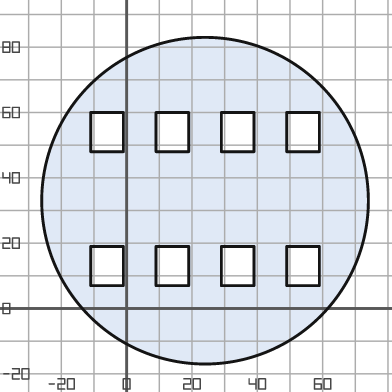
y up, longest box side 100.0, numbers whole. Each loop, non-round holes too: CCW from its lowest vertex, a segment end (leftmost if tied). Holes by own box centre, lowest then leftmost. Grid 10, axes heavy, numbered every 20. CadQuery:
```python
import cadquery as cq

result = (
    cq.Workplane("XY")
    .moveTo(24.0, 33.0)
    .circle(50.0)
    .moveTo(-11.0, 7.0)
    .lineTo(-1.0, 7.0)
    .lineTo(-1.0, 19.0)
    .lineTo(-11.0, 19.0)
    .close()
    .moveTo(9.0, 7.0)
    .lineTo(19.0, 7.0)
    .lineTo(19.0, 19.0)
    .lineTo(9.0, 19.0)
    .close()
    .moveTo(29.0, 7.0)
    .lineTo(39.0, 7.0)
    .lineTo(39.0, 19.0)
    .lineTo(29.0, 19.0)
    .close()
    .moveTo(49.0, 7.0)
    .lineTo(59.0, 7.0)
    .lineTo(59.0, 19.0)
    .lineTo(49.0, 19.0)
    .close()
    .moveTo(-11.0, 48.0)
    .lineTo(-1.0, 48.0)
    .lineTo(-1.0, 60.0)
    .lineTo(-11.0, 60.0)
    .close()
    .moveTo(9.0, 48.0)
    .lineTo(19.0, 48.0)
    .lineTo(19.0, 60.0)
    .lineTo(9.0, 60.0)
    .close()
    .moveTo(29.0, 48.0)
    .lineTo(39.0, 48.0)
    .lineTo(39.0, 60.0)
    .lineTo(29.0, 60.0)
    .close()
    .moveTo(49.0, 48.0)
    .lineTo(59.0, 48.0)
    .lineTo(59.0, 60.0)
    .lineTo(49.0, 60.0)
    .close()
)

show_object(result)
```